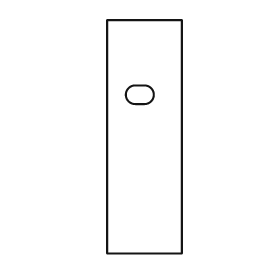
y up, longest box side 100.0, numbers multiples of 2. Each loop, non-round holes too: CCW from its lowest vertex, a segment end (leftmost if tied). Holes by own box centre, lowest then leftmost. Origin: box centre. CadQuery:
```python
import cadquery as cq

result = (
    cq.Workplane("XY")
    .moveTo(-16.0, -50.0)
    .lineTo(16.0, -50.0)
    .lineTo(16.0, 50.0)
    .lineTo(-16.0, 50.0)
    .close()
    .moveTo(-4.0, 14.0)
    .lineTo(0.0, 14.0)
    .threePointArc((4.0, 18.0), (0.0, 22.0))
    .lineTo(-4.0, 22.0)
    .threePointArc((-8.0, 18.0), (-4.0, 14.0))
    .close()
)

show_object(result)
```